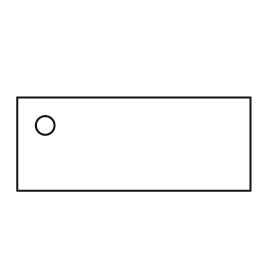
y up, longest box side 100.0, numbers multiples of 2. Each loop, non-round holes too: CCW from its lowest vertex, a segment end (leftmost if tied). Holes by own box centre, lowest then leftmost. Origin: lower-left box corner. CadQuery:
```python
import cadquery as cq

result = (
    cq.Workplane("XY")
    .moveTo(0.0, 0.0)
    .lineTo(100.0, 0.0)
    .lineTo(100.0, 40.0)
    .lineTo(0.0, 40.0)
    .close()
    .moveTo(12.0, 28.0)
    .circle(4.0)
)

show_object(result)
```